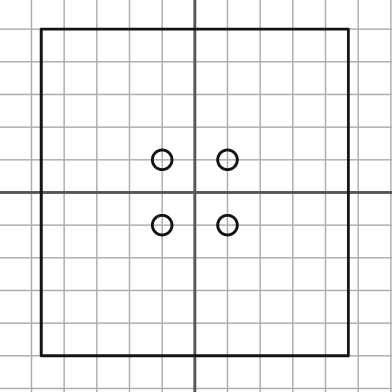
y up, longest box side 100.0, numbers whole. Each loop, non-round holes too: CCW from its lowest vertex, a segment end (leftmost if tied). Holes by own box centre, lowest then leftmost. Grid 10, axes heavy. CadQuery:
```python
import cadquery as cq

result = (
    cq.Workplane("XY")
    .moveTo(-47.0, -50.0)
    .lineTo(47.0, -50.0)
    .lineTo(47.0, 50.0)
    .lineTo(-47.0, 50.0)
    .close()
    .moveTo(-10.0, -10.0)
    .circle(3.0)
    .moveTo(10.0, -10.0)
    .circle(3.0)
    .moveTo(-10.0, 10.0)
    .circle(3.0)
    .moveTo(10.0, 10.0)
    .circle(3.0)
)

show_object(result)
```